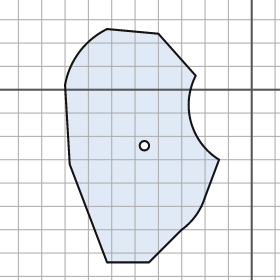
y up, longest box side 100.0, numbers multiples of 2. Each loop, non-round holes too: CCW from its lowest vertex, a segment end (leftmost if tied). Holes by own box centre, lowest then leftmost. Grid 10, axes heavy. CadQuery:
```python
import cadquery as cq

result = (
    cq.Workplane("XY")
    .moveTo(-62.0, -74.0)
    .lineTo(-44.0, -74.0)
    .lineTo(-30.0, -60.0)
    .threePointArc((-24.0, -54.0), (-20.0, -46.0))
    .lineTo(-14.0, -30.0)
    .threePointArc((-26.0, -14.0), (-24.0, 6.0))
    .lineTo(-40.0, 24.0)
    .lineTo(-62.0, 26.0)
    .threePointArc((-74.0, 16.0), (-80.0, 2.0))
    .lineTo(-78.0, -32.0)
    .close()
    .moveTo(-46.0, -24.0)
    .circle(2.0)
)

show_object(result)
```